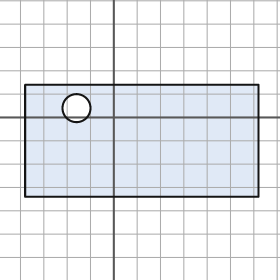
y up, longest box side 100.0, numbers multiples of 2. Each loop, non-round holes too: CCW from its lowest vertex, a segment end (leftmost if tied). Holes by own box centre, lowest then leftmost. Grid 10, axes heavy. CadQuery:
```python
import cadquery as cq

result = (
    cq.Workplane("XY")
    .moveTo(-38.0, -34.0)
    .lineTo(62.0, -34.0)
    .lineTo(62.0, 14.0)
    .lineTo(-38.0, 14.0)
    .close()
    .moveTo(-16.0, 4.0)
    .circle(6.0)
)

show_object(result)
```